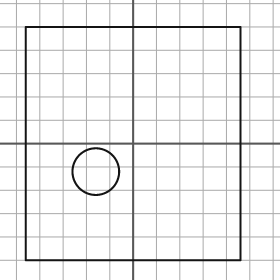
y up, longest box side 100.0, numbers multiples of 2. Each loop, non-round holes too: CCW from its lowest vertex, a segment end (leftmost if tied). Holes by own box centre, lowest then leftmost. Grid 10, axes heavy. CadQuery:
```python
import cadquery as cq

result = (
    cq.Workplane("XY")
    .moveTo(-46.0, -50.0)
    .lineTo(46.0, -50.0)
    .lineTo(46.0, 50.0)
    .lineTo(-46.0, 50.0)
    .close()
    .moveTo(-16.0, -12.0)
    .circle(10.0)
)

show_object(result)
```